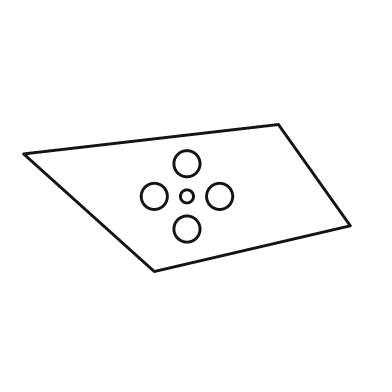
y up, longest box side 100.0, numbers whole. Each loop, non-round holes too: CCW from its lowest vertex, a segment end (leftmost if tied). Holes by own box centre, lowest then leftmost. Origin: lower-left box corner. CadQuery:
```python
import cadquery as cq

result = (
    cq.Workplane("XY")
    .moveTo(40.0, 0.0)
    .lineTo(100.0, 14.0)
    .lineTo(78.0, 45.0)
    .lineTo(0.0, 36.0)
    .close()
    .moveTo(50.0, 13.0)
    .circle(4.0)
    .moveTo(40.0, 23.0)
    .circle(4.0)
    .moveTo(50.0, 23.0)
    .circle(2.0)
    .moveTo(60.0, 23.0)
    .circle(4.0)
    .moveTo(50.0, 33.0)
    .circle(4.0)
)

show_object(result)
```